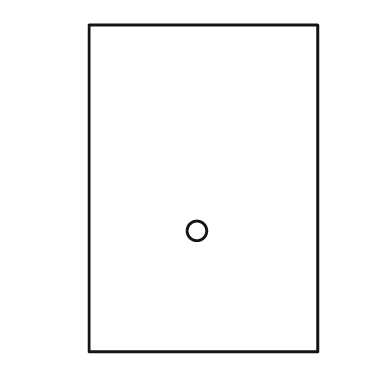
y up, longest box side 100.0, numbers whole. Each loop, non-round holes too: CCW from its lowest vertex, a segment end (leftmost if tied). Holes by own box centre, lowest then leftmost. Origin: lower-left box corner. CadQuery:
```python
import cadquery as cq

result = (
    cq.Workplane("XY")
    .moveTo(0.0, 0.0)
    .lineTo(70.0, 0.0)
    .lineTo(70.0, 100.0)
    .lineTo(0.0, 100.0)
    .close()
    .moveTo(33.0, 37.0)
    .circle(3.0)
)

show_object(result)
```